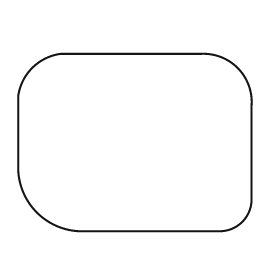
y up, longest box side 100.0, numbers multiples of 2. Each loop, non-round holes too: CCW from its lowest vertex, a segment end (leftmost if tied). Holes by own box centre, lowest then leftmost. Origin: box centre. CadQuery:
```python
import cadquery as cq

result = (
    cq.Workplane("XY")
    .moveTo(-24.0, -38.0)
    .lineTo(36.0, -38.0)
    .threePointArc((46.0, -34.0), (50.0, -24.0))
    .lineTo(50.0, 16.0)
    .threePointArc((44.0, 32.0), (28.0, 38.0))
    .lineTo(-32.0, 38.0)
    .threePointArc((-44.0, 32.0), (-50.0, 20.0))
    .lineTo(-50.0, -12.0)
    .threePointArc((-42.0, -30.0), (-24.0, -38.0))
    .close()
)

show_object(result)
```